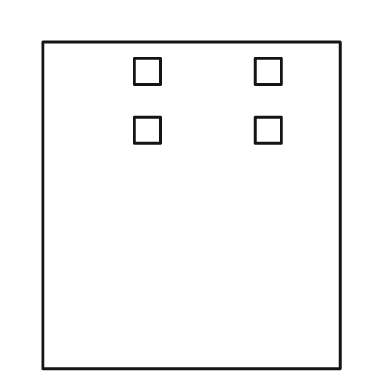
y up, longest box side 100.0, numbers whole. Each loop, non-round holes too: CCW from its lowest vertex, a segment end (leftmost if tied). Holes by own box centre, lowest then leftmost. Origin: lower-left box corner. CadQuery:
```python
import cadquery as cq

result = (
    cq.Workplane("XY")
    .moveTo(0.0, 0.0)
    .lineTo(91.0, 0.0)
    .lineTo(91.0, 100.0)
    .lineTo(0.0, 100.0)
    .close()
    .moveTo(28.0, 69.0)
    .lineTo(36.0, 69.0)
    .lineTo(36.0, 77.0)
    .lineTo(28.0, 77.0)
    .close()
    .moveTo(65.0, 69.0)
    .lineTo(73.0, 69.0)
    .lineTo(73.0, 77.0)
    .lineTo(65.0, 77.0)
    .close()
    .moveTo(28.0, 87.0)
    .lineTo(36.0, 87.0)
    .lineTo(36.0, 95.0)
    .lineTo(28.0, 95.0)
    .close()
    .moveTo(65.0, 87.0)
    .lineTo(73.0, 87.0)
    .lineTo(73.0, 95.0)
    .lineTo(65.0, 95.0)
    .close()
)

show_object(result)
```